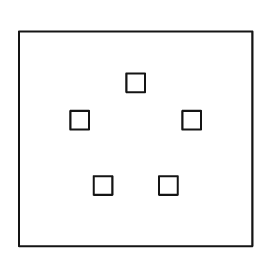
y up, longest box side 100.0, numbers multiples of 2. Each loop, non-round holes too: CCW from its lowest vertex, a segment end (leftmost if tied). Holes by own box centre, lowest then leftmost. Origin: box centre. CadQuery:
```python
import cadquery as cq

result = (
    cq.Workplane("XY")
    .moveTo(-50.0, -46.0)
    .lineTo(50.0, -46.0)
    .lineTo(50.0, 46.0)
    .lineTo(-50.0, 46.0)
    .close()
    .moveTo(-18.0, -24.0)
    .lineTo(-10.0, -24.0)
    .lineTo(-10.0, -16.0)
    .lineTo(-18.0, -16.0)
    .close()
    .moveTo(10.0, -24.0)
    .lineTo(18.0, -24.0)
    .lineTo(18.0, -16.0)
    .lineTo(10.0, -16.0)
    .close()
    .moveTo(-28.0, 4.0)
    .lineTo(-20.0, 4.0)
    .lineTo(-20.0, 12.0)
    .lineTo(-28.0, 12.0)
    .close()
    .moveTo(20.0, 4.0)
    .lineTo(28.0, 4.0)
    .lineTo(28.0, 12.0)
    .lineTo(20.0, 12.0)
    .close()
    .moveTo(-4.0, 20.0)
    .lineTo(4.0, 20.0)
    .lineTo(4.0, 28.0)
    .lineTo(-4.0, 28.0)
    .close()
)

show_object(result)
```